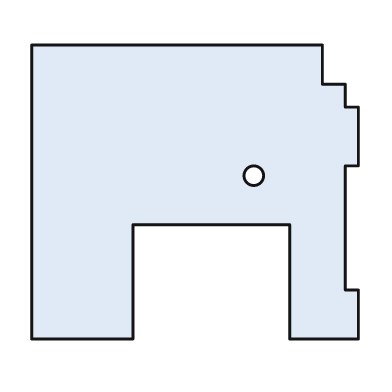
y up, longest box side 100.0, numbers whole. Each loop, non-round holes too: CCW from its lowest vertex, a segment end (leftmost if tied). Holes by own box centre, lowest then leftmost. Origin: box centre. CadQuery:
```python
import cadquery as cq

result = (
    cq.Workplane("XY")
    .moveTo(-50.0, -45.0)
    .lineTo(-19.0, -45.0)
    .lineTo(-19.0, -10.0)
    .lineTo(29.0, -10.0)
    .lineTo(29.0, -45.0)
    .lineTo(50.0, -45.0)
    .lineTo(50.0, -30.0)
    .lineTo(46.0, -30.0)
    .lineTo(46.0, 8.0)
    .lineTo(50.0, 8.0)
    .lineTo(50.0, 26.0)
    .lineTo(46.0, 26.0)
    .lineTo(46.0, 33.0)
    .lineTo(39.0, 33.0)
    .lineTo(39.0, 45.0)
    .lineTo(-50.0, 45.0)
    .close()
    .moveTo(18.0, 5.0)
    .circle(3.0)
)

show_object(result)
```